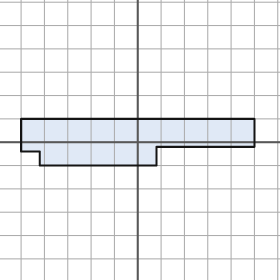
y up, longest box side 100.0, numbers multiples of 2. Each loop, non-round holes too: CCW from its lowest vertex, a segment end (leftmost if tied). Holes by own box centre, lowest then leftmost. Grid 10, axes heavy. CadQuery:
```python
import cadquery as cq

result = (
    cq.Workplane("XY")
    .moveTo(-42.0, -10.0)
    .lineTo(8.0, -10.0)
    .lineTo(8.0, -2.0)
    .lineTo(50.0, -2.0)
    .lineTo(50.0, 10.0)
    .lineTo(-50.0, 10.0)
    .lineTo(-50.0, -4.0)
    .lineTo(-42.0, -4.0)
    .close()
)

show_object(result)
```